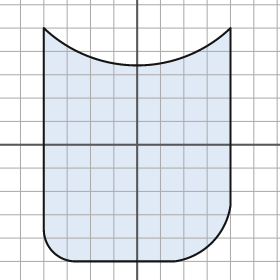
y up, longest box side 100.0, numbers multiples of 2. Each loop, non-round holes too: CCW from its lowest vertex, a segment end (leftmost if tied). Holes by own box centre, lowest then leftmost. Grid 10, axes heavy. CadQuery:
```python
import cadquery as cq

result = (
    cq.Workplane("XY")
    .moveTo(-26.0, -50.0)
    .lineTo(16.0, -50.0)
    .threePointArc((32.0, -42.0), (40.0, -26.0))
    .lineTo(40.0, 50.0)
    .threePointArc((0.0, 34.0), (-40.0, 50.0))
    .lineTo(-40.0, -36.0)
    .threePointArc((-36.0, -46.0), (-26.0, -50.0))
    .close()
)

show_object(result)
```